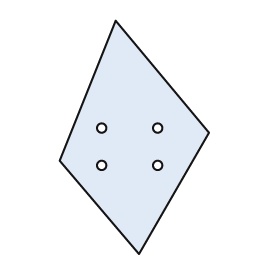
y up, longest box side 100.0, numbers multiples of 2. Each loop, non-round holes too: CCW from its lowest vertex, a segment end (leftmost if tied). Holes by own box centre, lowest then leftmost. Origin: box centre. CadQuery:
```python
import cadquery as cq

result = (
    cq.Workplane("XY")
    .moveTo(2.0, -50.0)
    .lineTo(32.0, 2.0)
    .lineTo(-8.0, 50.0)
    .lineTo(-32.0, -10.0)
    .close()
    .moveTo(-14.0, -12.0)
    .circle(2.0)
    .moveTo(10.0, -12.0)
    .circle(2.0)
    .moveTo(-14.0, 4.0)
    .circle(2.0)
    .moveTo(10.0, 4.0)
    .circle(2.0)
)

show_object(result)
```